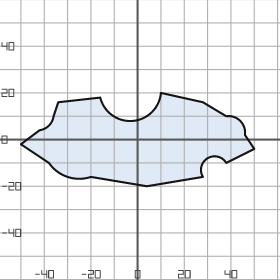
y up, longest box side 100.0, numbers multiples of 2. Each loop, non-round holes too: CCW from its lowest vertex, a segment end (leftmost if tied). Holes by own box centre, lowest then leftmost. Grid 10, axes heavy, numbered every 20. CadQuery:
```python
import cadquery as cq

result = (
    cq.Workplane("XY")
    .moveTo(4.0, -20.0)
    .lineTo(28.0, -16.0)
    .threePointArc((30.0, -8.0), (38.0, -10.0))
    .lineTo(50.0, -4.0)
    .lineTo(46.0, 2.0)
    .threePointArc((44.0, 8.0), (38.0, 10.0))
    .lineTo(28.0, 16.0)
    .lineTo(10.0, 20.0)
    .threePointArc((-2.0, 8.0), (-16.0, 18.0))
    .lineTo(-34.0, 16.0)
    .lineTo(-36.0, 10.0)
    .threePointArc((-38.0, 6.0), (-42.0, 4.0))
    .lineTo(-50.0, -2.0)
    .lineTo(-38.0, -10.0)
    .threePointArc((-30.0, -16.0), (-20.0, -16.0))
    .close()
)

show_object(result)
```